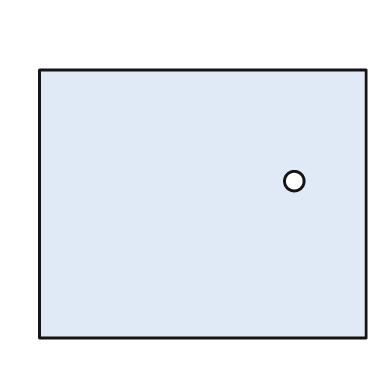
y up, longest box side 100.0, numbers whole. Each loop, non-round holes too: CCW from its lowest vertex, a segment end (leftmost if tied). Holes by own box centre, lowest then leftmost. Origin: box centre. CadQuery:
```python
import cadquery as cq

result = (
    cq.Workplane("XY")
    .moveTo(-50.0, -41.0)
    .lineTo(50.0, -41.0)
    .lineTo(50.0, 41.0)
    .lineTo(-50.0, 41.0)
    .close()
    .moveTo(28.0, 7.0)
    .circle(3.0)
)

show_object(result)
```